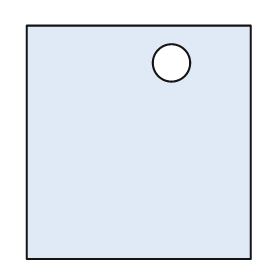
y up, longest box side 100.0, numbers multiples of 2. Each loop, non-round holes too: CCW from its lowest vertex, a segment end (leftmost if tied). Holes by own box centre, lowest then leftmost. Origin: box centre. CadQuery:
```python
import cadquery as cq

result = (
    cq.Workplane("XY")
    .moveTo(-48.0, -50.0)
    .lineTo(48.0, -50.0)
    .lineTo(48.0, 50.0)
    .lineTo(-48.0, 50.0)
    .close()
    .moveTo(14.0, 34.0)
    .circle(8.0)
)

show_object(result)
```